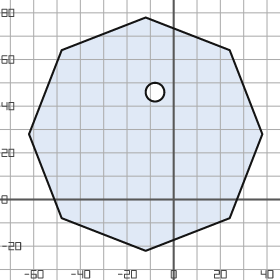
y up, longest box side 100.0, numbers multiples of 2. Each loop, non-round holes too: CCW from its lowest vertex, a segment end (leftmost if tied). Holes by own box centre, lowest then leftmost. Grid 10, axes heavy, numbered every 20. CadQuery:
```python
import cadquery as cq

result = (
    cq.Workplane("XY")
    .moveTo(-12.0, -22.0)
    .lineTo(24.0, -8.0)
    .lineTo(38.0, 28.0)
    .lineTo(24.0, 64.0)
    .lineTo(-12.0, 78.0)
    .lineTo(-48.0, 64.0)
    .lineTo(-62.0, 28.0)
    .lineTo(-48.0, -8.0)
    .close()
    .moveTo(-8.0, 46.0)
    .circle(4.0)
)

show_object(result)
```